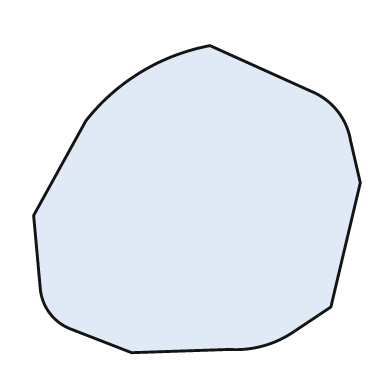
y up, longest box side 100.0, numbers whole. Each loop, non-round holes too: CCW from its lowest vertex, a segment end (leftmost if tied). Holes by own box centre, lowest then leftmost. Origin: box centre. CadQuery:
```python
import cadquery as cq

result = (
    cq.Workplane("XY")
    .moveTo(-20.0, -47.0)
    .lineTo(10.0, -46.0)
    .threePointArc((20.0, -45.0), (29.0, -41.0))
    .lineTo(41.0, -33.0)
    .lineTo(50.0, 5.0)
    .lineTo(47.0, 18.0)
    .threePointArc((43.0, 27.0), (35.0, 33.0))
    .lineTo(4.0, 47.0)
    .threePointArc((-17.0, 39.0), (-34.0, 24.0))
    .lineTo(-50.0, -5.0)
    .lineTo(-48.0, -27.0)
    .threePointArc((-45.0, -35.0), (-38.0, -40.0))
    .close()
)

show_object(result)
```